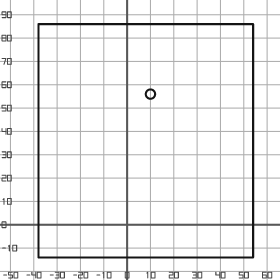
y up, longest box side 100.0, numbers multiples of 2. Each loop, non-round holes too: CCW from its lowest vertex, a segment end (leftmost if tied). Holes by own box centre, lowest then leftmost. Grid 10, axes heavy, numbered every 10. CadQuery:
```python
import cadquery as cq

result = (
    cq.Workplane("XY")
    .moveTo(-38.0, -14.0)
    .lineTo(54.0, -14.0)
    .lineTo(54.0, 86.0)
    .lineTo(-38.0, 86.0)
    .close()
    .moveTo(10.0, 56.0)
    .circle(2.0)
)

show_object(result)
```